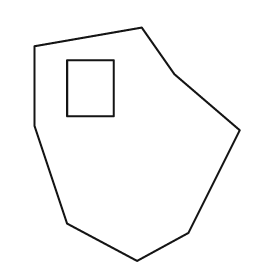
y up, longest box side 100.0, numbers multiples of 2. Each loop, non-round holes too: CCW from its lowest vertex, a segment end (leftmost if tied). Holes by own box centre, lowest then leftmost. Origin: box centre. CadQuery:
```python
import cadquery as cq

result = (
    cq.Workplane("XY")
    .moveTo(0.0, -50.0)
    .lineTo(22.0, -38.0)
    .lineTo(44.0, 6.0)
    .lineTo(16.0, 30.0)
    .lineTo(2.0, 50.0)
    .lineTo(-44.0, 42.0)
    .lineTo(-44.0, 8.0)
    .lineTo(-30.0, -34.0)
    .close()
    .moveTo(-30.0, 12.0)
    .lineTo(-10.0, 12.0)
    .lineTo(-10.0, 36.0)
    .lineTo(-30.0, 36.0)
    .close()
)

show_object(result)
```